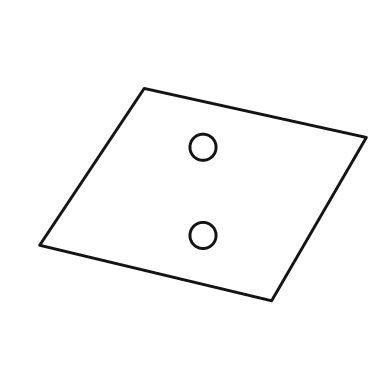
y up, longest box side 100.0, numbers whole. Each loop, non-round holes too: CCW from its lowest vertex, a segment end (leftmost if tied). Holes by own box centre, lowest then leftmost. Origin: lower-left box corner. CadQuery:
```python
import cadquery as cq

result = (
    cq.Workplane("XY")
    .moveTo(71.0, 0.0)
    .lineTo(100.0, 50.0)
    .lineTo(32.0, 65.0)
    .lineTo(0.0, 17.0)
    .close()
    .moveTo(50.0, 20.0)
    .circle(4.0)
    .moveTo(50.0, 47.0)
    .circle(4.0)
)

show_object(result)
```